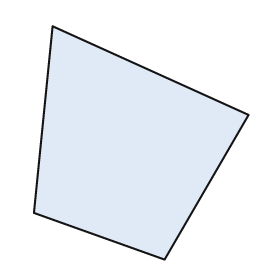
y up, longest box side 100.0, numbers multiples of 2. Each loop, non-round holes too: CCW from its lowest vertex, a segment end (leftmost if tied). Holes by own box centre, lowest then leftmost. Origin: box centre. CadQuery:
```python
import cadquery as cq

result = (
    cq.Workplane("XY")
    .moveTo(10.0, -50.0)
    .lineTo(46.0, 12.0)
    .lineTo(-38.0, 50.0)
    .lineTo(-46.0, -30.0)
    .close()
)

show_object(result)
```